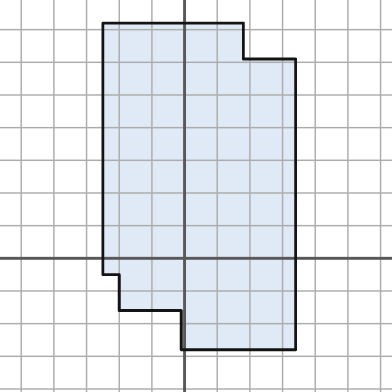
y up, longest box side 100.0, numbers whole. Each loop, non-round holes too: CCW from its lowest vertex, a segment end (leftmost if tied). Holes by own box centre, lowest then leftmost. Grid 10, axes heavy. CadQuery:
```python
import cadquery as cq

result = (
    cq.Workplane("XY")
    .moveTo(-1.0, -28.0)
    .lineTo(34.0, -28.0)
    .lineTo(34.0, 61.0)
    .lineTo(18.0, 61.0)
    .lineTo(18.0, 72.0)
    .lineTo(-25.0, 72.0)
    .lineTo(-25.0, -5.0)
    .lineTo(-20.0, -5.0)
    .lineTo(-20.0, -16.0)
    .lineTo(-1.0, -16.0)
    .close()
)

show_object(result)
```